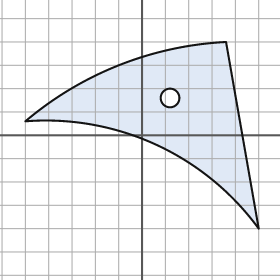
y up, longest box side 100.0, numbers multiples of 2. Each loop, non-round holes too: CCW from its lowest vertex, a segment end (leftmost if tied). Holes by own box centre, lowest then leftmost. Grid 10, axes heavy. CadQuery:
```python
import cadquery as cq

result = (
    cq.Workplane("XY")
    .moveTo(50.0, -40.0)
    .lineTo(36.0, 40.0)
    .threePointArc((-10.0, 30.0), (-50.0, 6.0))
    .threePointArc((6.0, -4.0), (50.0, -40.0))
    .close()
    .moveTo(12.0, 16.0)
    .circle(4.0)
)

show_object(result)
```